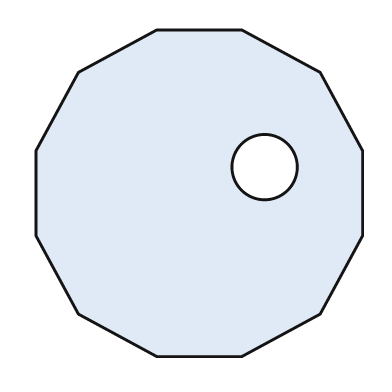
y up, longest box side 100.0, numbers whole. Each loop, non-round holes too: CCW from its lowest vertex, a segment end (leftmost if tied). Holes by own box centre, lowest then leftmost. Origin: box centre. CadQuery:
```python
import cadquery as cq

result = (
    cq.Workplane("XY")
    .moveTo(-13.0, -50.0)
    .lineTo(13.0, -50.0)
    .lineTo(37.0, -37.0)
    .lineTo(50.0, -13.0)
    .lineTo(50.0, 13.0)
    .lineTo(37.0, 37.0)
    .lineTo(13.0, 50.0)
    .lineTo(-13.0, 50.0)
    .lineTo(-37.0, 37.0)
    .lineTo(-50.0, 13.0)
    .lineTo(-50.0, -13.0)
    .lineTo(-37.0, -37.0)
    .close()
    .moveTo(20.0, 8.0)
    .circle(10.0)
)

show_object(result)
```